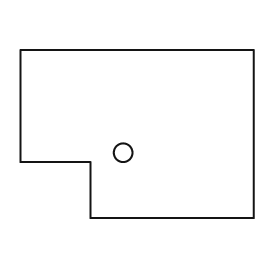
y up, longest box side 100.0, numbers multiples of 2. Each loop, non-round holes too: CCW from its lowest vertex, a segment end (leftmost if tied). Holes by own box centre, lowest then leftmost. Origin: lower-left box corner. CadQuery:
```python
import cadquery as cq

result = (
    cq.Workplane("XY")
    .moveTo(30.0, 0.0)
    .lineTo(100.0, 0.0)
    .lineTo(100.0, 72.0)
    .lineTo(0.0, 72.0)
    .lineTo(0.0, 24.0)
    .lineTo(30.0, 24.0)
    .close()
    .moveTo(44.0, 28.0)
    .circle(4.0)
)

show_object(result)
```